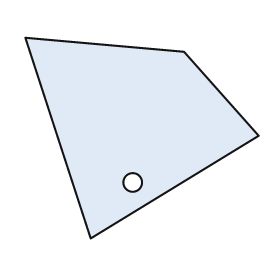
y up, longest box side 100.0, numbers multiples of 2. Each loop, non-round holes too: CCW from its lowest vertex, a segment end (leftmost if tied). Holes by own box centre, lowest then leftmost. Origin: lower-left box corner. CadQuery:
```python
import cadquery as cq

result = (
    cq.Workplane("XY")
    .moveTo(28.0, 0.0)
    .lineTo(100.0, 44.0)
    .lineTo(68.0, 80.0)
    .lineTo(0.0, 86.0)
    .close()
    .moveTo(46.0, 24.0)
    .circle(4.0)
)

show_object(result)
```